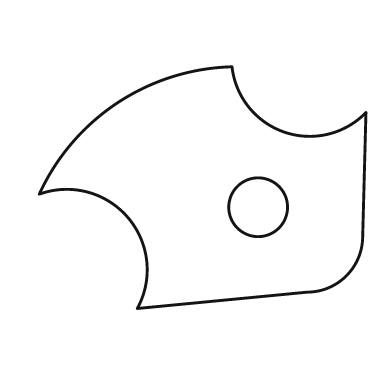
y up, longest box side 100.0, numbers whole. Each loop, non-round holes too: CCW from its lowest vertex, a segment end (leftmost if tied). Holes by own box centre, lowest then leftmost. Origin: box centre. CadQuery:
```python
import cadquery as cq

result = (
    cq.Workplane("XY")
    .moveTo(-20.0, -37.0)
    .lineTo(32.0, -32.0)
    .threePointArc((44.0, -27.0), (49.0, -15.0))
    .lineTo(50.0, 23.0)
    .threePointArc((25.0, 17.0), (9.0, 37.0))
    .threePointArc((-26.0, 26.0), (-50.0, -2.0))
    .threePointArc((-23.0, -9.0), (-20.0, -37.0))
    .close()
    .moveTo(17.0, -6.0)
    .circle(9.0)
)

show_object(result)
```